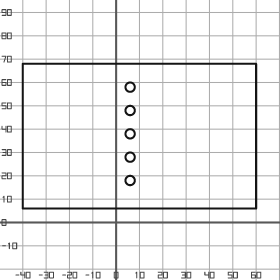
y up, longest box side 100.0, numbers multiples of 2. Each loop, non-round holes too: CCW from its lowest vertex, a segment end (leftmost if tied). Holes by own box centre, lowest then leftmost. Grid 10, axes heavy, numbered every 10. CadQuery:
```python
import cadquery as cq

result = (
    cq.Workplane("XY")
    .moveTo(-40.0, 6.0)
    .lineTo(60.0, 6.0)
    .lineTo(60.0, 68.0)
    .lineTo(-40.0, 68.0)
    .close()
    .moveTo(6.0, 18.0)
    .circle(2.0)
    .moveTo(6.0, 28.0)
    .circle(2.0)
    .moveTo(6.0, 38.0)
    .circle(2.0)
    .moveTo(6.0, 48.0)
    .circle(2.0)
    .moveTo(6.0, 58.0)
    .circle(2.0)
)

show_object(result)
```